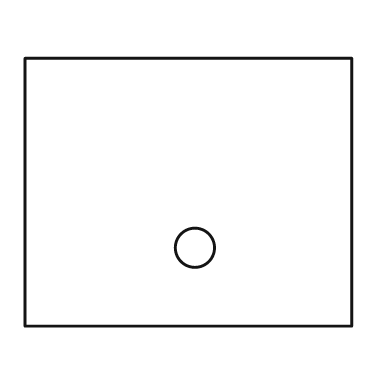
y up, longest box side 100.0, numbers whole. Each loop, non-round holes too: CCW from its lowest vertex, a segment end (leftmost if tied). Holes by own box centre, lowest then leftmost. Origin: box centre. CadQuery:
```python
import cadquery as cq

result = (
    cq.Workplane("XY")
    .moveTo(-50.0, -41.0)
    .lineTo(50.0, -41.0)
    .lineTo(50.0, 41.0)
    .lineTo(-50.0, 41.0)
    .close()
    .moveTo(2.0, -17.0)
    .circle(6.0)
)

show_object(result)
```